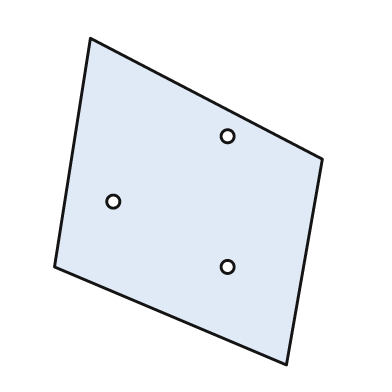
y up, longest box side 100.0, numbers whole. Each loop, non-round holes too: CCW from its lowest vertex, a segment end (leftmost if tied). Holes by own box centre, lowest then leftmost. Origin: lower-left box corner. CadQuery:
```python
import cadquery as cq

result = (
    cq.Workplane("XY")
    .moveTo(71.0, 0.0)
    .lineTo(82.0, 63.0)
    .lineTo(11.0, 100.0)
    .lineTo(0.0, 30.0)
    .close()
    .moveTo(53.0, 30.0)
    .circle(2.0)
    .moveTo(18.0, 50.0)
    .circle(2.0)
    .moveTo(53.0, 70.0)
    .circle(2.0)
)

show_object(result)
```